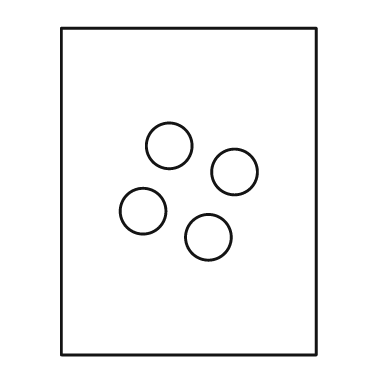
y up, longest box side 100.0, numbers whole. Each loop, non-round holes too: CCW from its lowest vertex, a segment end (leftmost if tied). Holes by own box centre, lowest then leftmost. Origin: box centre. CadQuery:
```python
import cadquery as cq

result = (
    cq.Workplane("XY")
    .moveTo(-39.0, -50.0)
    .lineTo(39.0, -50.0)
    .lineTo(39.0, 50.0)
    .lineTo(-39.0, 50.0)
    .close()
    .moveTo(6.0, -14.0)
    .circle(7.0)
    .moveTo(-14.0, -6.0)
    .circle(7.0)
    .moveTo(14.0, 6.0)
    .circle(7.0)
    .moveTo(-6.0, 14.0)
    .circle(7.0)
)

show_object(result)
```